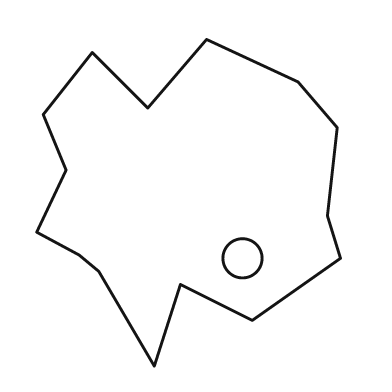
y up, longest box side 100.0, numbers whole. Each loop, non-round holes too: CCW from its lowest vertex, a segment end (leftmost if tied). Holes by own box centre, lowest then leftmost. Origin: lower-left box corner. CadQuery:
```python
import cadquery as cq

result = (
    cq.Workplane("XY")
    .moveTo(36.0, 0.0)
    .lineTo(44.0, 25.0)
    .lineTo(66.0, 14.0)
    .lineTo(93.0, 33.0)
    .lineTo(89.0, 46.0)
    .lineTo(92.0, 73.0)
    .lineTo(80.0, 87.0)
    .lineTo(52.0, 100.0)
    .lineTo(34.0, 79.0)
    .lineTo(17.0, 96.0)
    .lineTo(2.0, 77.0)
    .lineTo(9.0, 60.0)
    .lineTo(0.0, 41.0)
    .lineTo(13.0, 34.0)
    .lineTo(19.0, 29.0)
    .close()
    .moveTo(63.0, 33.0)
    .circle(6.0)
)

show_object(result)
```